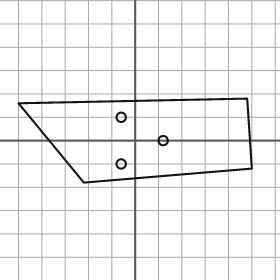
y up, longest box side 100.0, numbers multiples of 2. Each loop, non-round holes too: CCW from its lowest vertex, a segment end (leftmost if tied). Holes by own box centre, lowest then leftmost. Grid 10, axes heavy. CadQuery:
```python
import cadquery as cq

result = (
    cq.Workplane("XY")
    .moveTo(-22.0, -18.0)
    .lineTo(50.0, -12.0)
    .lineTo(48.0, 18.0)
    .lineTo(-50.0, 16.0)
    .close()
    .moveTo(-6.0, -10.0)
    .circle(2.0)
    .moveTo(12.0, 0.0)
    .circle(2.0)
    .moveTo(-6.0, 10.0)
    .circle(2.0)
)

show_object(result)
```